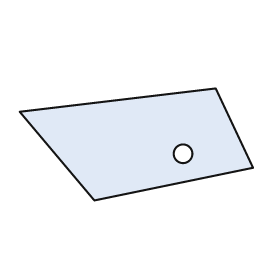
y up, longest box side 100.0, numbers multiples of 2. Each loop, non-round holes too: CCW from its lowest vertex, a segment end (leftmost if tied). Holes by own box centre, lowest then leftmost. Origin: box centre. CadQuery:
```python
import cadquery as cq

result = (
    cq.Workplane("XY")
    .moveTo(-18.0, -24.0)
    .lineTo(50.0, -10.0)
    .lineTo(34.0, 24.0)
    .lineTo(-50.0, 14.0)
    .close()
    .moveTo(20.0, -4.0)
    .circle(4.0)
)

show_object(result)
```